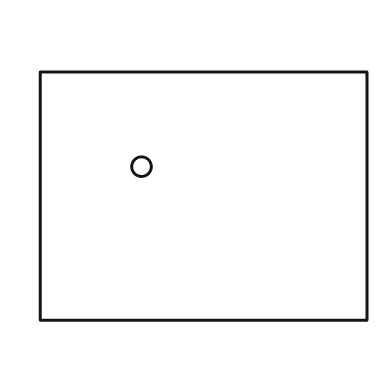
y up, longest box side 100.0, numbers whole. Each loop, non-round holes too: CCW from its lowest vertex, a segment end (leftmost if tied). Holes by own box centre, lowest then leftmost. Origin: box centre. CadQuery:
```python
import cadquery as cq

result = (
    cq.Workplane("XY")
    .moveTo(-50.0, -38.0)
    .lineTo(50.0, -38.0)
    .lineTo(50.0, 38.0)
    .lineTo(-50.0, 38.0)
    .close()
    .moveTo(-19.0, 9.0)
    .circle(3.0)
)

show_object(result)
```